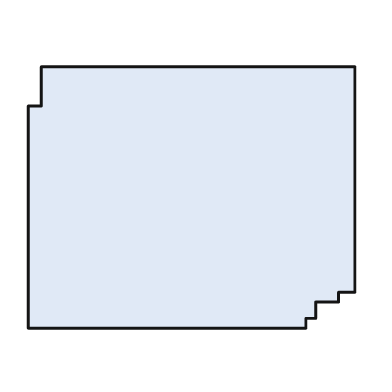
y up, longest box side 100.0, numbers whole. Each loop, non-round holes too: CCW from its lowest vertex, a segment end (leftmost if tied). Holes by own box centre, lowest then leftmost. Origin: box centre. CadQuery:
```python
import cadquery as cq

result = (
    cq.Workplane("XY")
    .moveTo(-50.0, -40.0)
    .lineTo(35.0, -40.0)
    .lineTo(35.0, -37.0)
    .lineTo(38.0, -37.0)
    .lineTo(38.0, -32.0)
    .lineTo(45.0, -32.0)
    .lineTo(45.0, -29.0)
    .lineTo(50.0, -29.0)
    .lineTo(50.0, 40.0)
    .lineTo(-46.0, 40.0)
    .lineTo(-46.0, 28.0)
    .lineTo(-50.0, 28.0)
    .close()
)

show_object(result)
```